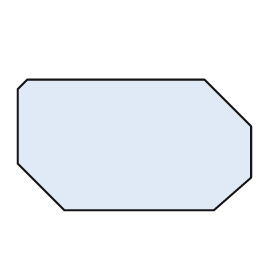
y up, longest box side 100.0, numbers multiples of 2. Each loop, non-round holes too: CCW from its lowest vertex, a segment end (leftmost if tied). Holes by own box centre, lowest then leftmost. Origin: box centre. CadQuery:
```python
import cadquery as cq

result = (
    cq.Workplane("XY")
    .moveTo(-30.0, -28.0)
    .lineTo(34.0, -28.0)
    .lineTo(50.0, -14.0)
    .lineTo(50.0, 8.0)
    .lineTo(30.0, 28.0)
    .lineTo(-46.0, 28.0)
    .lineTo(-50.0, 24.0)
    .lineTo(-50.0, -8.0)
    .close()
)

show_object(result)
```